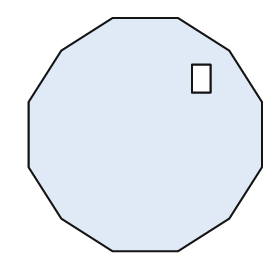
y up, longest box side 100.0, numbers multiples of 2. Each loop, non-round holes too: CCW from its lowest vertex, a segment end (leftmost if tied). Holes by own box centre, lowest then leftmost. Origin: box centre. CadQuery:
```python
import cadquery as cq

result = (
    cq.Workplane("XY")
    .moveTo(-14.0, -50.0)
    .lineTo(14.0, -50.0)
    .lineTo(36.0, -36.0)
    .lineTo(50.0, -14.0)
    .lineTo(50.0, 14.0)
    .lineTo(36.0, 36.0)
    .lineTo(14.0, 50.0)
    .lineTo(-14.0, 50.0)
    .lineTo(-36.0, 36.0)
    .lineTo(-50.0, 14.0)
    .lineTo(-50.0, -14.0)
    .lineTo(-36.0, -36.0)
    .close()
    .moveTo(20.0, 18.0)
    .lineTo(28.0, 18.0)
    .lineTo(28.0, 30.0)
    .lineTo(20.0, 30.0)
    .close()
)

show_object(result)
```